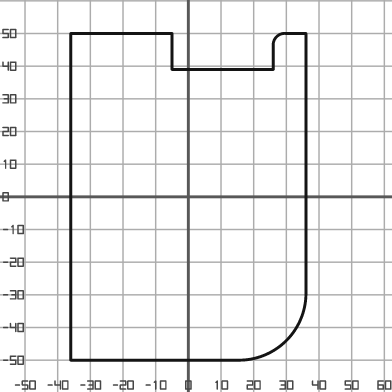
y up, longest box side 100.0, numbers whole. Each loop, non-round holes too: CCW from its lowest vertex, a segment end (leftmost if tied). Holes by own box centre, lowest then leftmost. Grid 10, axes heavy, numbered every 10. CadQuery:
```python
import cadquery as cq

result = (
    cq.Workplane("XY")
    .moveTo(-36.0, -50.0)
    .lineTo(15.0, -50.0)
    .threePointArc((30.0, -44.0), (36.0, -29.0))
    .lineTo(36.0, 50.0)
    .lineTo(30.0, 50.0)
    .threePointArc((27.0, 49.0), (26.0, 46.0))
    .lineTo(26.0, 39.0)
    .lineTo(-5.0, 39.0)
    .lineTo(-5.0, 50.0)
    .lineTo(-36.0, 50.0)
    .close()
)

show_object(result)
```